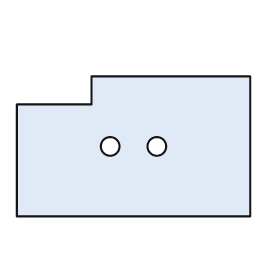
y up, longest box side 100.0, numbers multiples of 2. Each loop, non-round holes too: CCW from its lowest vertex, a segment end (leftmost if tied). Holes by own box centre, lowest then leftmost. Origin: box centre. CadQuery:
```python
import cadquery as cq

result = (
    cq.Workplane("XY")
    .moveTo(-50.0, -30.0)
    .lineTo(50.0, -30.0)
    .lineTo(50.0, 30.0)
    .lineTo(-18.0, 30.0)
    .lineTo(-18.0, 18.0)
    .lineTo(-50.0, 18.0)
    .close()
    .moveTo(-10.0, 0.0)
    .circle(4.0)
    .moveTo(10.0, 0.0)
    .circle(4.0)
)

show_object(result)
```